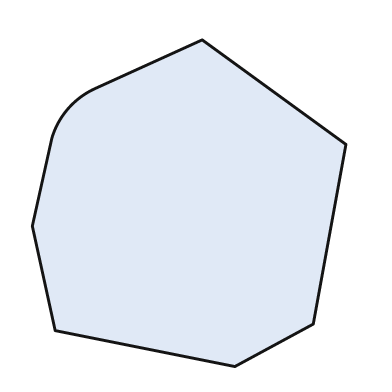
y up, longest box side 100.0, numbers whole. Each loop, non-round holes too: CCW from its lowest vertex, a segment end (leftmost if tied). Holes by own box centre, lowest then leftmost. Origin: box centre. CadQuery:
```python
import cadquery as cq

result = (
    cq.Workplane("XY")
    .moveTo(14.0, -50.0)
    .lineTo(38.0, -37.0)
    .lineTo(48.0, 18.0)
    .lineTo(4.0, 50.0)
    .lineTo(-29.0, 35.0)
    .threePointArc((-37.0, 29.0), (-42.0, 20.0))
    .lineTo(-48.0, -7.0)
    .lineTo(-41.0, -39.0)
    .close()
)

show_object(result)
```